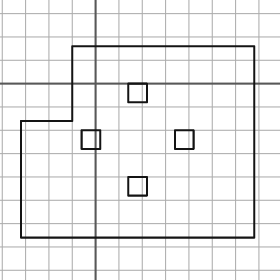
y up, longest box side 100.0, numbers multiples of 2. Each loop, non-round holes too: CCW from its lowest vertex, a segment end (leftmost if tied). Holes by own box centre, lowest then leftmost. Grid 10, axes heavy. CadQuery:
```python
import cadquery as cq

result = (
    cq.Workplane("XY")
    .moveTo(-32.0, -66.0)
    .lineTo(68.0, -66.0)
    .lineTo(68.0, 16.0)
    .lineTo(-10.0, 16.0)
    .lineTo(-10.0, -16.0)
    .lineTo(-32.0, -16.0)
    .close()
    .moveTo(14.0, -48.0)
    .lineTo(22.0, -48.0)
    .lineTo(22.0, -40.0)
    .lineTo(14.0, -40.0)
    .close()
    .moveTo(-6.0, -28.0)
    .lineTo(2.0, -28.0)
    .lineTo(2.0, -20.0)
    .lineTo(-6.0, -20.0)
    .close()
    .moveTo(34.0, -28.0)
    .lineTo(42.0, -28.0)
    .lineTo(42.0, -20.0)
    .lineTo(34.0, -20.0)
    .close()
    .moveTo(14.0, -8.0)
    .lineTo(22.0, -8.0)
    .lineTo(22.0, 0.0)
    .lineTo(14.0, 0.0)
    .close()
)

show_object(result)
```